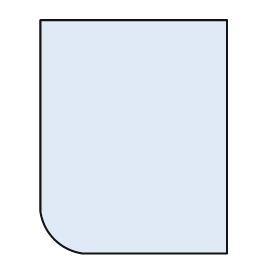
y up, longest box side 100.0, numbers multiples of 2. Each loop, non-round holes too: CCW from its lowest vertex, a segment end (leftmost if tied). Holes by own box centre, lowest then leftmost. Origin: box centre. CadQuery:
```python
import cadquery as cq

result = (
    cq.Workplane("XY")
    .moveTo(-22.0, -50.0)
    .lineTo(40.0, -50.0)
    .lineTo(40.0, 50.0)
    .lineTo(-40.0, 50.0)
    .lineTo(-40.0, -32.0)
    .threePointArc((-34.0, -44.0), (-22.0, -50.0))
    .close()
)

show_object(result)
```